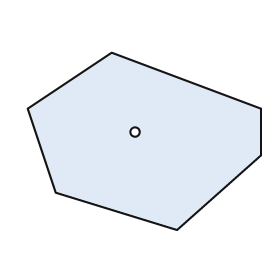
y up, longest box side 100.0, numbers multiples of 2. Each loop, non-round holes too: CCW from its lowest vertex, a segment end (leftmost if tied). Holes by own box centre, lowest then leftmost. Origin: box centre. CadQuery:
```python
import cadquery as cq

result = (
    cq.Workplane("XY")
    .moveTo(14.0, -38.0)
    .lineTo(50.0, -6.0)
    .lineTo(50.0, 14.0)
    .lineTo(-14.0, 38.0)
    .lineTo(-50.0, 14.0)
    .lineTo(-38.0, -22.0)
    .close()
    .moveTo(-4.0, 4.0)
    .circle(2.0)
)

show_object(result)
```